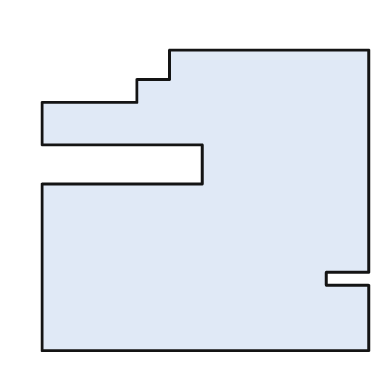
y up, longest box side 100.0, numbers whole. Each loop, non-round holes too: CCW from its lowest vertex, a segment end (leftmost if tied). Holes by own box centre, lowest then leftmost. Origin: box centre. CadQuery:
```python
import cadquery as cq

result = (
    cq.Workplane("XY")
    .moveTo(-50.0, -46.0)
    .lineTo(50.0, -46.0)
    .lineTo(50.0, -26.0)
    .lineTo(37.0, -26.0)
    .lineTo(37.0, -22.0)
    .lineTo(50.0, -22.0)
    .lineTo(50.0, 46.0)
    .lineTo(-11.0, 46.0)
    .lineTo(-11.0, 37.0)
    .lineTo(-21.0, 37.0)
    .lineTo(-21.0, 30.0)
    .lineTo(-50.0, 30.0)
    .lineTo(-50.0, 17.0)
    .lineTo(-1.0, 17.0)
    .lineTo(-1.0, 5.0)
    .lineTo(-50.0, 5.0)
    .close()
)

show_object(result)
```